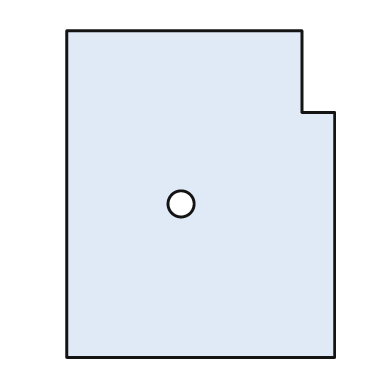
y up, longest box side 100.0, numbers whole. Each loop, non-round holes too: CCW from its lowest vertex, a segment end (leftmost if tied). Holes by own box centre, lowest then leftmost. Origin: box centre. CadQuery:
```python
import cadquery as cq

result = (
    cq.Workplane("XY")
    .moveTo(-41.0, -50.0)
    .lineTo(41.0, -50.0)
    .lineTo(41.0, 25.0)
    .lineTo(31.0, 25.0)
    .lineTo(31.0, 50.0)
    .lineTo(-41.0, 50.0)
    .close()
    .moveTo(-6.0, -3.0)
    .circle(4.0)
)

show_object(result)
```